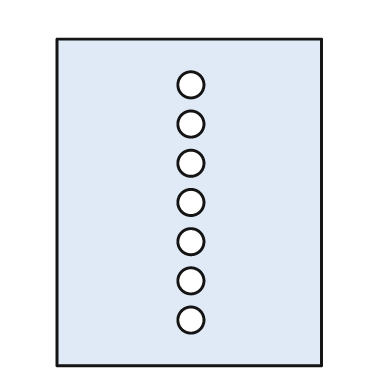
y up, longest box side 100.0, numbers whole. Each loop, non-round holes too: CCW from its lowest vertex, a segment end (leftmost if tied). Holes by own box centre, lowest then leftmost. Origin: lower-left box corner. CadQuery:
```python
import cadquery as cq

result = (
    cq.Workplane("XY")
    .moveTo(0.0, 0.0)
    .lineTo(81.0, 0.0)
    .lineTo(81.0, 100.0)
    .lineTo(0.0, 100.0)
    .close()
    .moveTo(41.0, 14.0)
    .circle(4.0)
    .moveTo(41.0, 26.0)
    .circle(4.0)
    .moveTo(41.0, 38.0)
    .circle(4.0)
    .moveTo(41.0, 50.0)
    .circle(4.0)
    .moveTo(41.0, 62.0)
    .circle(4.0)
    .moveTo(41.0, 74.0)
    .circle(4.0)
    .moveTo(41.0, 86.0)
    .circle(4.0)
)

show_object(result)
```